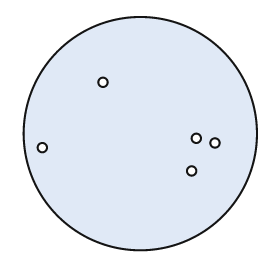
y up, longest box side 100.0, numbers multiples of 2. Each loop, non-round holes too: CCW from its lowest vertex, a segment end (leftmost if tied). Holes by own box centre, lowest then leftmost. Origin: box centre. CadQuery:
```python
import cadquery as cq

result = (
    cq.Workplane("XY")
    .moveTo(0.0, 0.0)
    .circle(50.0)
    .moveTo(22.0, -16.0)
    .circle(2.0)
    .moveTo(-42.0, -6.0)
    .circle(2.0)
    .moveTo(32.0, -4.0)
    .circle(2.0)
    .moveTo(24.0, -2.0)
    .circle(2.0)
    .moveTo(-16.0, 22.0)
    .circle(2.0)
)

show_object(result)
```